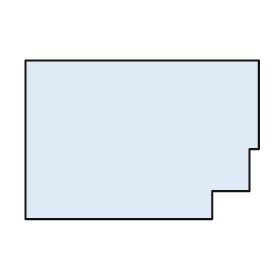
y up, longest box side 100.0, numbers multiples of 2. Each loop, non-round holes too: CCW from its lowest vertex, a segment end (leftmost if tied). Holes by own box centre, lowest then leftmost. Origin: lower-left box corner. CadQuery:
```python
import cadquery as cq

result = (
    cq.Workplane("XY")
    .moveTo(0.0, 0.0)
    .lineTo(80.0, 0.0)
    .lineTo(80.0, 12.0)
    .lineTo(96.0, 12.0)
    .lineTo(96.0, 30.0)
    .lineTo(100.0, 30.0)
    .lineTo(100.0, 68.0)
    .lineTo(0.0, 68.0)
    .close()
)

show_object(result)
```